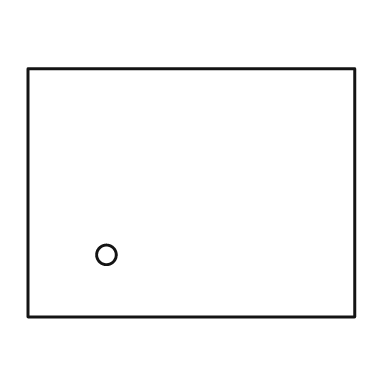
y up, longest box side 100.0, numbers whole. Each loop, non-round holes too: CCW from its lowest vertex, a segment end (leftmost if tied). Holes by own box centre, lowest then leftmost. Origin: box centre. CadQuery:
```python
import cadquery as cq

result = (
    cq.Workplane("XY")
    .moveTo(-50.0, -38.0)
    .lineTo(50.0, -38.0)
    .lineTo(50.0, 38.0)
    .lineTo(-50.0, 38.0)
    .close()
    .moveTo(-26.0, -19.0)
    .circle(3.0)
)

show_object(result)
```